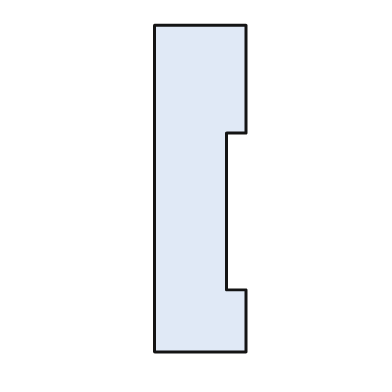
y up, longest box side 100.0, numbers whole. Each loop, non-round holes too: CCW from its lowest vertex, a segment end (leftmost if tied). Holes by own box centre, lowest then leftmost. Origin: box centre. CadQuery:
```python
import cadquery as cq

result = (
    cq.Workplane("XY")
    .moveTo(-14.0, -50.0)
    .lineTo(14.0, -50.0)
    .lineTo(14.0, -31.0)
    .lineTo(8.0, -31.0)
    .lineTo(8.0, 17.0)
    .lineTo(14.0, 17.0)
    .lineTo(14.0, 50.0)
    .lineTo(-14.0, 50.0)
    .close()
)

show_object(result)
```